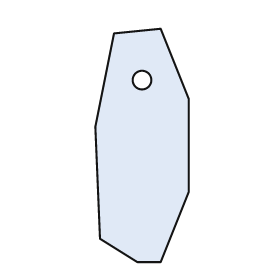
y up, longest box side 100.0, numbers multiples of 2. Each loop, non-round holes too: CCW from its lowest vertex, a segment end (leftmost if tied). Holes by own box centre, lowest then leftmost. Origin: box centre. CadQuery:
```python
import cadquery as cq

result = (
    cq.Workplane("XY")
    .moveTo(-2.0, -50.0)
    .lineTo(8.0, -50.0)
    .lineTo(20.0, -20.0)
    .lineTo(20.0, 20.0)
    .lineTo(8.0, 50.0)
    .lineTo(-12.0, 48.0)
    .lineTo(-20.0, 8.0)
    .lineTo(-18.0, -40.0)
    .close()
    .moveTo(0.0, 28.0)
    .circle(4.0)
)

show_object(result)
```